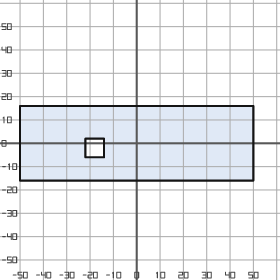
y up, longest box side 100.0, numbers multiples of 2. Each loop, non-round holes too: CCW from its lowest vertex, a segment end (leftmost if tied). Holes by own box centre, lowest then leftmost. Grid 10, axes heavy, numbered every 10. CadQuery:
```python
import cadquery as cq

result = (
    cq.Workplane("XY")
    .moveTo(-50.0, -16.0)
    .lineTo(50.0, -16.0)
    .lineTo(50.0, 16.0)
    .lineTo(-50.0, 16.0)
    .close()
    .moveTo(-22.0, -6.0)
    .lineTo(-14.0, -6.0)
    .lineTo(-14.0, 2.0)
    .lineTo(-22.0, 2.0)
    .close()
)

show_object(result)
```